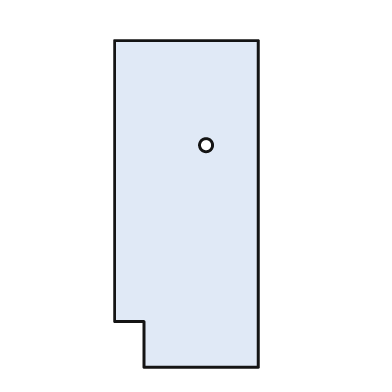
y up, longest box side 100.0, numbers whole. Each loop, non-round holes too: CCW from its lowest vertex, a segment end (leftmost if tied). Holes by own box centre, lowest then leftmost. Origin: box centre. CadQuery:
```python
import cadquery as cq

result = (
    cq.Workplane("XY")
    .moveTo(-13.0, -50.0)
    .lineTo(22.0, -50.0)
    .lineTo(22.0, 50.0)
    .lineTo(-22.0, 50.0)
    .lineTo(-22.0, -36.0)
    .lineTo(-13.0, -36.0)
    .close()
    .moveTo(6.0, 18.0)
    .circle(2.0)
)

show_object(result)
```